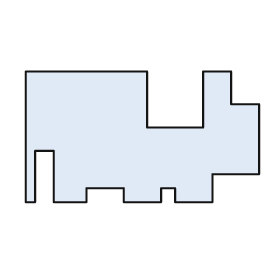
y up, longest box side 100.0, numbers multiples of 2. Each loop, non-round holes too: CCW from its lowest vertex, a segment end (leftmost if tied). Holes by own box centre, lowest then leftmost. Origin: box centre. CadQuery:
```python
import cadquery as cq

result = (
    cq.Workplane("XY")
    .moveTo(-50.0, -28.0)
    .lineTo(-46.0, -28.0)
    .lineTo(-46.0, -6.0)
    .lineTo(-38.0, -6.0)
    .lineTo(-38.0, -28.0)
    .lineTo(-24.0, -28.0)
    .lineTo(-24.0, -22.0)
    .lineTo(-8.0, -22.0)
    .lineTo(-8.0, -28.0)
    .lineTo(8.0, -28.0)
    .lineTo(8.0, -22.0)
    .lineTo(14.0, -22.0)
    .lineTo(14.0, -28.0)
    .lineTo(30.0, -28.0)
    .lineTo(30.0, -16.0)
    .lineTo(50.0, -16.0)
    .lineTo(50.0, 14.0)
    .lineTo(38.0, 14.0)
    .lineTo(38.0, 28.0)
    .lineTo(26.0, 28.0)
    .lineTo(26.0, 4.0)
    .lineTo(2.0, 4.0)
    .lineTo(2.0, 28.0)
    .lineTo(-50.0, 28.0)
    .close()
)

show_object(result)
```